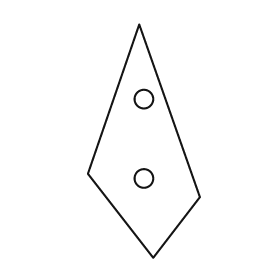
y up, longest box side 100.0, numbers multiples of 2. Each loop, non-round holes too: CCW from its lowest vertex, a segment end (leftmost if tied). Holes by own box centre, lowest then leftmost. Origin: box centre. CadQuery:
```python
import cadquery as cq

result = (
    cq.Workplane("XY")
    .moveTo(4.0, -50.0)
    .lineTo(24.0, -24.0)
    .lineTo(-2.0, 50.0)
    .lineTo(-24.0, -14.0)
    .close()
    .moveTo(0.0, -16.0)
    .circle(4.0)
    .moveTo(0.0, 18.0)
    .circle(4.0)
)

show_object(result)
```